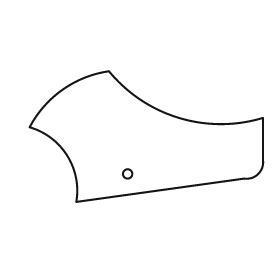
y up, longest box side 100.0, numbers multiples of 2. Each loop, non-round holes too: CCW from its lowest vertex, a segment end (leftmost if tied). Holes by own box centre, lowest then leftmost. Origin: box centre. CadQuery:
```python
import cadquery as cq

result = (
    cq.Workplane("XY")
    .moveTo(-30.0, -28.0)
    .lineTo(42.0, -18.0)
    .threePointArc((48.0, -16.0), (50.0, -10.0))
    .lineTo(50.0, 8.0)
    .threePointArc((14.0, 8.0), (-16.0, 28.0))
    .threePointArc((-36.0, 20.0), (-50.0, 4.0))
    .threePointArc((-34.0, -8.0), (-30.0, -28.0))
    .close()
    .moveTo(-8.0, -16.0)
    .circle(2.0)
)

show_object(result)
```